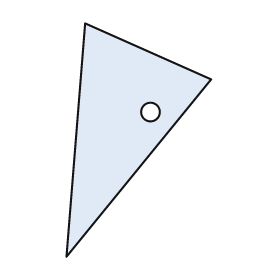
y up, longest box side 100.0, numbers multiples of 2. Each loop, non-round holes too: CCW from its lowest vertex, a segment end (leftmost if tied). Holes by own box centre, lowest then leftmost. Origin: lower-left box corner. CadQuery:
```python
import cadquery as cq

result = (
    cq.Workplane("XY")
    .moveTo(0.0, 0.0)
    .lineTo(62.0, 76.0)
    .lineTo(8.0, 100.0)
    .close()
    .moveTo(36.0, 62.0)
    .circle(4.0)
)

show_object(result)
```